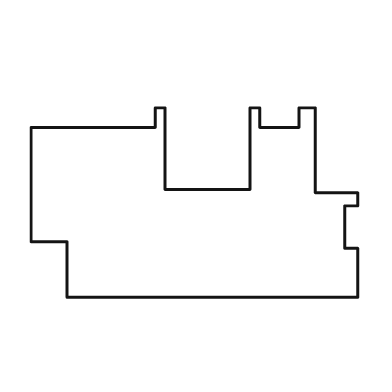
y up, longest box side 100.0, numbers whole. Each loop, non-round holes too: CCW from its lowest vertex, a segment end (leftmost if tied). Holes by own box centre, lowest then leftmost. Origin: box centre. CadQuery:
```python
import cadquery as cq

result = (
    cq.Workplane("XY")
    .moveTo(-39.0, -29.0)
    .lineTo(50.0, -29.0)
    .lineTo(50.0, -14.0)
    .lineTo(46.0, -14.0)
    .lineTo(46.0, -1.0)
    .lineTo(50.0, -1.0)
    .lineTo(50.0, 3.0)
    .lineTo(37.0, 3.0)
    .lineTo(37.0, 29.0)
    .lineTo(32.0, 29.0)
    .lineTo(32.0, 23.0)
    .lineTo(20.0, 23.0)
    .lineTo(20.0, 29.0)
    .lineTo(17.0, 29.0)
    .lineTo(17.0, 4.0)
    .lineTo(-9.0, 4.0)
    .lineTo(-9.0, 29.0)
    .lineTo(-12.0, 29.0)
    .lineTo(-12.0, 23.0)
    .lineTo(-50.0, 23.0)
    .lineTo(-50.0, -12.0)
    .lineTo(-39.0, -12.0)
    .close()
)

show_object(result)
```